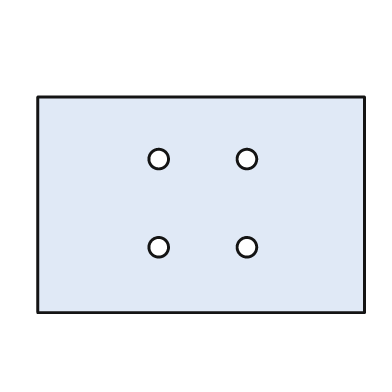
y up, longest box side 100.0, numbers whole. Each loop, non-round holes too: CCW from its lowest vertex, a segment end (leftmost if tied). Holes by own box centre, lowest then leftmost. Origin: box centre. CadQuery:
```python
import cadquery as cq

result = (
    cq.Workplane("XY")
    .moveTo(-50.0, -33.0)
    .lineTo(50.0, -33.0)
    .lineTo(50.0, 33.0)
    .lineTo(-50.0, 33.0)
    .close()
    .moveTo(-13.0, -13.0)
    .circle(3.0)
    .moveTo(14.0, -13.0)
    .circle(3.0)
    .moveTo(-13.0, 14.0)
    .circle(3.0)
    .moveTo(14.0, 14.0)
    .circle(3.0)
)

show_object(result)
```